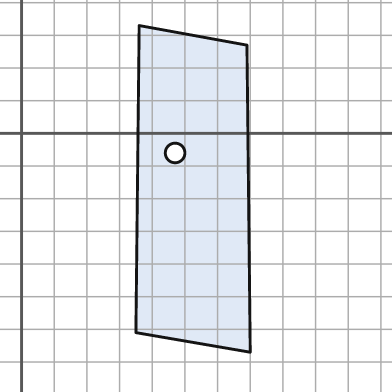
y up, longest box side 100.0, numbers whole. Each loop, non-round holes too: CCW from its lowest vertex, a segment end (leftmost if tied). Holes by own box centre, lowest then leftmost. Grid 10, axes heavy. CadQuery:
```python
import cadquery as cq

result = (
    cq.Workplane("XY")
    .moveTo(70.0, -67.0)
    .lineTo(69.0, 27.0)
    .lineTo(36.0, 33.0)
    .lineTo(35.0, -61.0)
    .close()
    .moveTo(47.0, -6.0)
    .circle(3.0)
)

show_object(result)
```